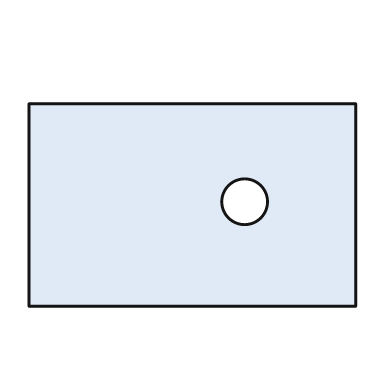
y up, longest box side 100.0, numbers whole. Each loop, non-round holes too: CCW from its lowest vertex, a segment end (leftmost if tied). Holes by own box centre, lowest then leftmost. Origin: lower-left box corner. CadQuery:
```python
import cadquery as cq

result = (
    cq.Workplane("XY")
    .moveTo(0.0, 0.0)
    .lineTo(100.0, 0.0)
    .lineTo(100.0, 62.0)
    .lineTo(0.0, 62.0)
    .close()
    .moveTo(66.0, 32.0)
    .circle(7.0)
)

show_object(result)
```